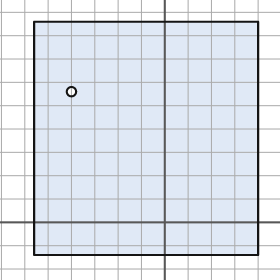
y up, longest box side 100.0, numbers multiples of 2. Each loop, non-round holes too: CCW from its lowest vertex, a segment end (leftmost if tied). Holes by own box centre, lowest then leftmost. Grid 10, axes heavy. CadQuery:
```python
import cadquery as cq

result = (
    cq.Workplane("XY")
    .moveTo(-56.0, -14.0)
    .lineTo(40.0, -14.0)
    .lineTo(40.0, 86.0)
    .lineTo(-56.0, 86.0)
    .close()
    .moveTo(-40.0, 56.0)
    .circle(2.0)
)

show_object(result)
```